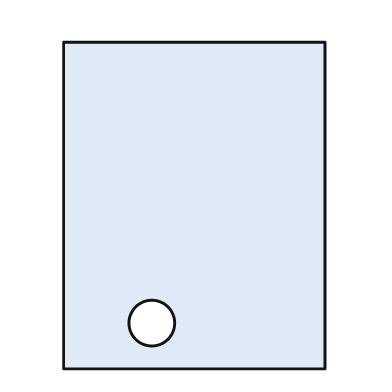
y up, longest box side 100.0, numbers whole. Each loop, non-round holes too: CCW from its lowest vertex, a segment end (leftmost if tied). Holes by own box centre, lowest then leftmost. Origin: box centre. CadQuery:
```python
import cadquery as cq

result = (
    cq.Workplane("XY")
    .moveTo(-40.0, -50.0)
    .lineTo(40.0, -50.0)
    .lineTo(40.0, 50.0)
    .lineTo(-40.0, 50.0)
    .close()
    .moveTo(-13.0, -36.0)
    .circle(7.0)
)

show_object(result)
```